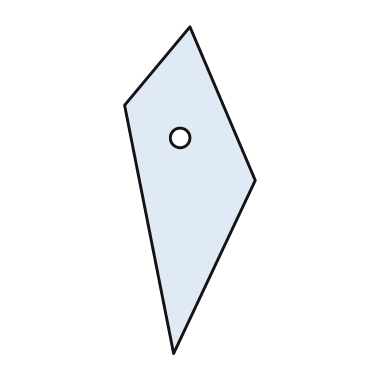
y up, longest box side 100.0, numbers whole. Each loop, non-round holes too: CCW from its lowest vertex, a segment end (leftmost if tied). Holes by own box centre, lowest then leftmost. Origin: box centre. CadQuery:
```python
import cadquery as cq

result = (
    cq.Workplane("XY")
    .moveTo(-5.0, -50.0)
    .lineTo(20.0, 3.0)
    .lineTo(0.0, 50.0)
    .lineTo(-20.0, 26.0)
    .close()
    .moveTo(-3.0, 16.0)
    .circle(3.0)
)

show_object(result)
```